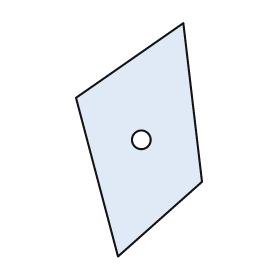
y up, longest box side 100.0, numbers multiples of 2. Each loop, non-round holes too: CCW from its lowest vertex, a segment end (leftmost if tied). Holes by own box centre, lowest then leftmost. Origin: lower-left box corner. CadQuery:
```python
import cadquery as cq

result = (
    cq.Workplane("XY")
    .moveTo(18.0, 0.0)
    .lineTo(54.0, 32.0)
    .lineTo(46.0, 100.0)
    .lineTo(0.0, 68.0)
    .close()
    .moveTo(28.0, 50.0)
    .circle(4.0)
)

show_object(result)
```